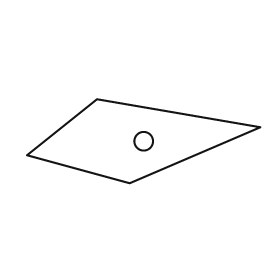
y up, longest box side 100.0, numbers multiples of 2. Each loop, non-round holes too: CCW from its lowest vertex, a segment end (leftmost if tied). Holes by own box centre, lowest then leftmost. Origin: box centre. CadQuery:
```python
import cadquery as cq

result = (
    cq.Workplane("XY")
    .moveTo(-6.0, -18.0)
    .lineTo(50.0, 6.0)
    .lineTo(-20.0, 18.0)
    .lineTo(-50.0, -6.0)
    .close()
    .moveTo(0.0, 0.0)
    .circle(4.0)
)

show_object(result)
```